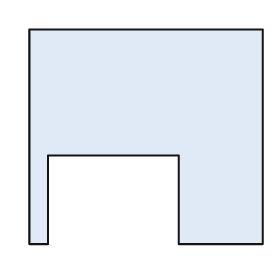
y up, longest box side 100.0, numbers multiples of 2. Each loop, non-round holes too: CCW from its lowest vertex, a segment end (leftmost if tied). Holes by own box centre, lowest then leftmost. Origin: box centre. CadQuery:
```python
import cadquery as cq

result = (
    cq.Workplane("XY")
    .moveTo(-50.0, -46.0)
    .lineTo(-42.0, -46.0)
    .lineTo(-42.0, -8.0)
    .lineTo(14.0, -8.0)
    .lineTo(14.0, -46.0)
    .lineTo(50.0, -46.0)
    .lineTo(50.0, 46.0)
    .lineTo(-50.0, 46.0)
    .close()
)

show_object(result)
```